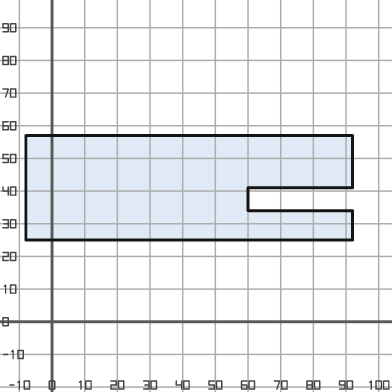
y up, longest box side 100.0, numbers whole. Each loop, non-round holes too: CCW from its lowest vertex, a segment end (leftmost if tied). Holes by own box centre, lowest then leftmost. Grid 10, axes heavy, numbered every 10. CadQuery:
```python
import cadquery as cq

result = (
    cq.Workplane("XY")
    .moveTo(-8.0, 25.0)
    .lineTo(92.0, 25.0)
    .lineTo(92.0, 34.0)
    .lineTo(60.0, 34.0)
    .lineTo(60.0, 41.0)
    .lineTo(92.0, 41.0)
    .lineTo(92.0, 57.0)
    .lineTo(-8.0, 57.0)
    .close()
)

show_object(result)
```